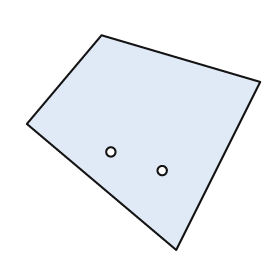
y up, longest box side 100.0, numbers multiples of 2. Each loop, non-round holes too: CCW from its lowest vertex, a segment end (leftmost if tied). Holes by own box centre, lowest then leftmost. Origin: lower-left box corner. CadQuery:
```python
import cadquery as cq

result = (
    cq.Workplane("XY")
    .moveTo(64.0, 0.0)
    .lineTo(100.0, 72.0)
    .lineTo(32.0, 92.0)
    .lineTo(0.0, 54.0)
    .close()
    .moveTo(58.0, 34.0)
    .circle(2.0)
    .moveTo(36.0, 42.0)
    .circle(2.0)
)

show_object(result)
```